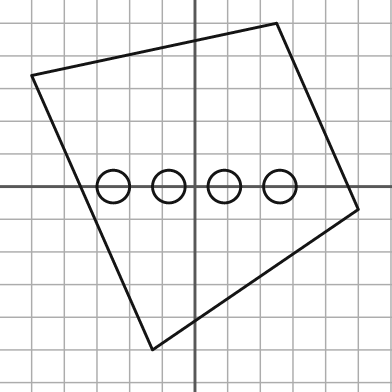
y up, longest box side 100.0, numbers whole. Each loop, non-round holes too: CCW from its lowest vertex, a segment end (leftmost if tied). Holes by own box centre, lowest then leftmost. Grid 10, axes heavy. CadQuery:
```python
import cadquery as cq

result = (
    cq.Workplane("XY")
    .moveTo(-13.0, -50.0)
    .lineTo(50.0, -7.0)
    .lineTo(25.0, 50.0)
    .lineTo(-50.0, 34.0)
    .close()
    .moveTo(-25.0, 0.0)
    .circle(5.0)
    .moveTo(-8.0, 0.0)
    .circle(5.0)
    .moveTo(9.0, 0.0)
    .circle(5.0)
    .moveTo(26.0, 0.0)
    .circle(5.0)
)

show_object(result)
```